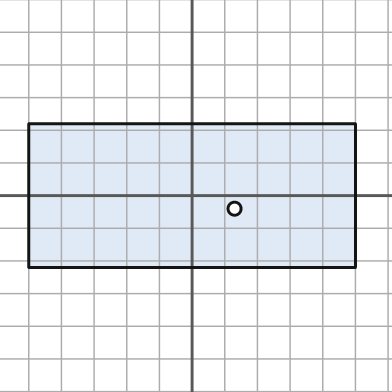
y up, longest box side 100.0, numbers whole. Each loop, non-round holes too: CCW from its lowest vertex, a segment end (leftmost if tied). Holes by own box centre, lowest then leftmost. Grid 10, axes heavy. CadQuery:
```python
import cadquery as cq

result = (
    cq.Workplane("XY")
    .moveTo(-50.0, -22.0)
    .lineTo(50.0, -22.0)
    .lineTo(50.0, 22.0)
    .lineTo(-50.0, 22.0)
    .close()
    .moveTo(13.0, -4.0)
    .circle(2.0)
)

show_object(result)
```